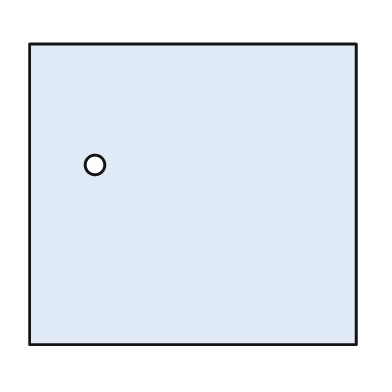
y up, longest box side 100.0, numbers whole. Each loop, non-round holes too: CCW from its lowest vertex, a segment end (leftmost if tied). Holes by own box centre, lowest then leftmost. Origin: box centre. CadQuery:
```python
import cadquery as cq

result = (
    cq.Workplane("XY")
    .moveTo(-50.0, -46.0)
    .lineTo(50.0, -46.0)
    .lineTo(50.0, 46.0)
    .lineTo(-50.0, 46.0)
    .close()
    .moveTo(-30.0, 9.0)
    .circle(3.0)
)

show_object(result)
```